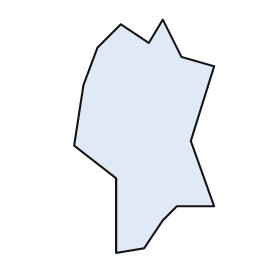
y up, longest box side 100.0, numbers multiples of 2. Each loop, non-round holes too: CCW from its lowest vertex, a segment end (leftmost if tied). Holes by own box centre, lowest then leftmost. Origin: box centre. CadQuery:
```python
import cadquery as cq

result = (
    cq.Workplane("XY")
    .moveTo(-12.0, -50.0)
    .lineTo(0.0, -48.0)
    .lineTo(8.0, -36.0)
    .lineTo(14.0, -30.0)
    .lineTo(30.0, -30.0)
    .lineTo(20.0, -2.0)
    .lineTo(30.0, 30.0)
    .lineTo(16.0, 34.0)
    .lineTo(8.0, 50.0)
    .lineTo(2.0, 40.0)
    .lineTo(-10.0, 48.0)
    .lineTo(-20.0, 38.0)
    .lineTo(-26.0, 22.0)
    .lineTo(-30.0, -4.0)
    .lineTo(-12.0, -18.0)
    .close()
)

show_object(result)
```